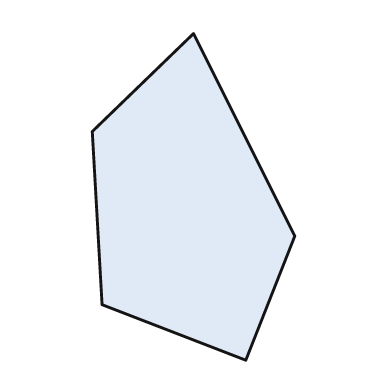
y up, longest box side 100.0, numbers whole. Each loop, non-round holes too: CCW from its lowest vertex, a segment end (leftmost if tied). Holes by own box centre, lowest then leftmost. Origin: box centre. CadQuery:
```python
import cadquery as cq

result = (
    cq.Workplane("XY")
    .moveTo(16.0, -50.0)
    .lineTo(31.0, -12.0)
    .lineTo(0.0, 50.0)
    .lineTo(-31.0, 20.0)
    .lineTo(-28.0, -33.0)
    .close()
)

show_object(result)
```